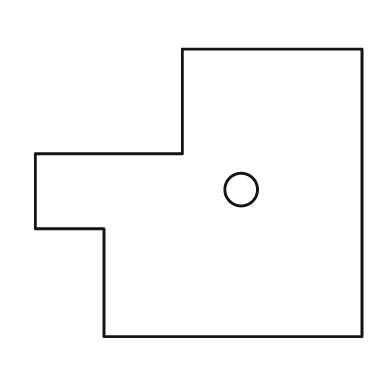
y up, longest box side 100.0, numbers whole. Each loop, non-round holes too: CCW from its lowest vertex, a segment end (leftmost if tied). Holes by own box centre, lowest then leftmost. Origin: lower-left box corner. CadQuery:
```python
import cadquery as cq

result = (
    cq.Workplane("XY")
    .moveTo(21.0, 0.0)
    .lineTo(100.0, 0.0)
    .lineTo(100.0, 88.0)
    .lineTo(45.0, 88.0)
    .lineTo(45.0, 56.0)
    .lineTo(0.0, 56.0)
    .lineTo(0.0, 33.0)
    .lineTo(21.0, 33.0)
    .close()
    .moveTo(63.0, 45.0)
    .circle(5.0)
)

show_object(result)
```